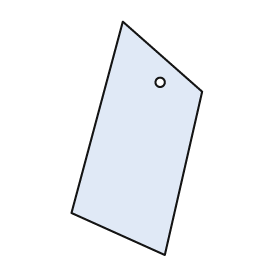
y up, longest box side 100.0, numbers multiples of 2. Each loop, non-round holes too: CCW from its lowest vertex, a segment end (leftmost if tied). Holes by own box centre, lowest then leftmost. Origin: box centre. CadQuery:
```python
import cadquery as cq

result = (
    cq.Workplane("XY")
    .moveTo(12.0, -50.0)
    .lineTo(28.0, 20.0)
    .lineTo(-6.0, 50.0)
    .lineTo(-28.0, -32.0)
    .close()
    .moveTo(10.0, 24.0)
    .circle(2.0)
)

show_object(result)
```